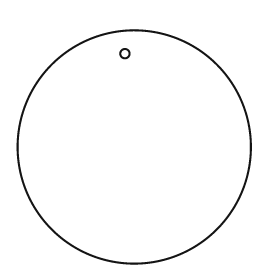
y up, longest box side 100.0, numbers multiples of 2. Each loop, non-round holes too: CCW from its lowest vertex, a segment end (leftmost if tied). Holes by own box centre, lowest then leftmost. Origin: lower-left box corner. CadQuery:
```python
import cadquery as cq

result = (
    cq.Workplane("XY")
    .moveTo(50.0, 50.0)
    .circle(50.0)
    .moveTo(46.0, 90.0)
    .circle(2.0)
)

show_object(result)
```